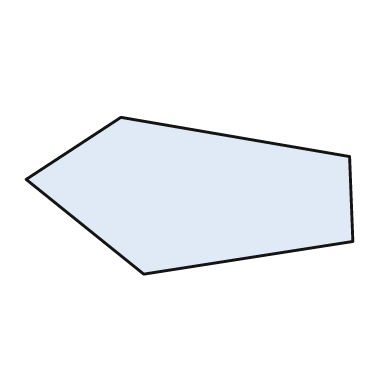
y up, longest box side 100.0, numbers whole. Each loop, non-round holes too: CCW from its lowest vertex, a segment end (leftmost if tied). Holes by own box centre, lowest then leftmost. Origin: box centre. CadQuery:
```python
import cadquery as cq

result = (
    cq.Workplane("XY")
    .moveTo(-14.0, -24.0)
    .lineTo(50.0, -14.0)
    .lineTo(49.0, 12.0)
    .lineTo(-21.0, 24.0)
    .lineTo(-50.0, 5.0)
    .close()
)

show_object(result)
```